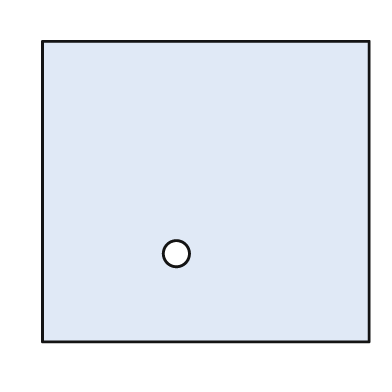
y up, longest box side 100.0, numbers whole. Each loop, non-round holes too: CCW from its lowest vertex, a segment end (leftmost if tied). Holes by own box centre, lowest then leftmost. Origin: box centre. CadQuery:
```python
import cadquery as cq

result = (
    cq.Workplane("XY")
    .moveTo(-50.0, -46.0)
    .lineTo(50.0, -46.0)
    .lineTo(50.0, 46.0)
    .lineTo(-50.0, 46.0)
    .close()
    .moveTo(-9.0, -19.0)
    .circle(4.0)
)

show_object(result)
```